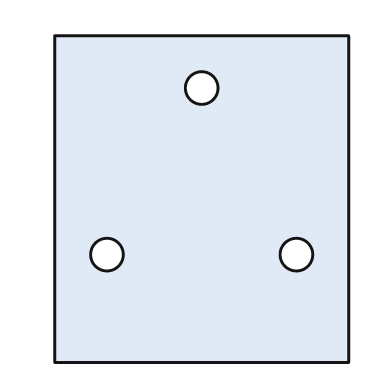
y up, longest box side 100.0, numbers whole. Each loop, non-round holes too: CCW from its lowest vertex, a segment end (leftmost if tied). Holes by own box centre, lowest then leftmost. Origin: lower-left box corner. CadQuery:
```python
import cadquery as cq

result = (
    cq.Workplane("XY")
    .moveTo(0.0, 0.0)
    .lineTo(90.0, 0.0)
    .lineTo(90.0, 100.0)
    .lineTo(0.0, 100.0)
    .close()
    .moveTo(16.0, 33.0)
    .circle(5.0)
    .moveTo(74.0, 33.0)
    .circle(5.0)
    .moveTo(45.0, 84.0)
    .circle(5.0)
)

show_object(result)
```